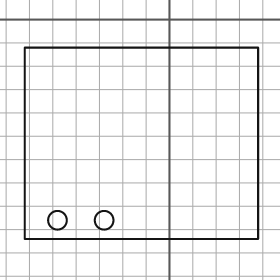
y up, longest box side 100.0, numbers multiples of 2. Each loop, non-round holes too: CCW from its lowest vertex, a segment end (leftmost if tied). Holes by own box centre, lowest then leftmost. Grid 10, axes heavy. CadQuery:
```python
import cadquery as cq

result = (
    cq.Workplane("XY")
    .moveTo(-62.0, -94.0)
    .lineTo(38.0, -94.0)
    .lineTo(38.0, -12.0)
    .lineTo(-62.0, -12.0)
    .close()
    .moveTo(-48.0, -86.0)
    .circle(4.0)
    .moveTo(-28.0, -86.0)
    .circle(4.0)
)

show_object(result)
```